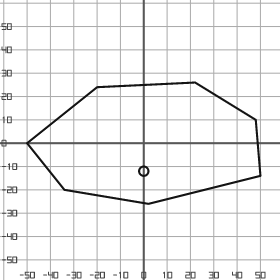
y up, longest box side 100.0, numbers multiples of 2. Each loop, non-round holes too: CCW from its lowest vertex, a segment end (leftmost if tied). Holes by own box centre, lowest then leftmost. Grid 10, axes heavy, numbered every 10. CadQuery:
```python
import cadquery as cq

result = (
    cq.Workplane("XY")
    .moveTo(2.0, -26.0)
    .lineTo(50.0, -14.0)
    .lineTo(48.0, 10.0)
    .lineTo(22.0, 26.0)
    .lineTo(-20.0, 24.0)
    .lineTo(-50.0, 0.0)
    .lineTo(-34.0, -20.0)
    .close()
    .moveTo(0.0, -12.0)
    .circle(2.0)
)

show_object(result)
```